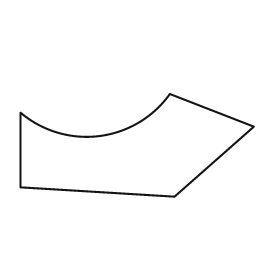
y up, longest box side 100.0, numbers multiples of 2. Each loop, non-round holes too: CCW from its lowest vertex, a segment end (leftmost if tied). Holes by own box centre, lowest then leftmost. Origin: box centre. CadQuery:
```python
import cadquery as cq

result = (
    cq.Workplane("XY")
    .moveTo(16.0, -22.0)
    .lineTo(50.0, 8.0)
    .lineTo(14.0, 22.0)
    .threePointArc((-16.0, 4.0), (-50.0, 14.0))
    .lineTo(-50.0, -18.0)
    .close()
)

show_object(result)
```